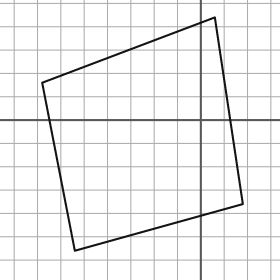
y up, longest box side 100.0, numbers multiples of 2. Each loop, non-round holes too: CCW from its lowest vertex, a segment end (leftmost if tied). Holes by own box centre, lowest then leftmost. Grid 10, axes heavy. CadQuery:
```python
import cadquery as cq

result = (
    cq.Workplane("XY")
    .moveTo(-54.0, -56.0)
    .lineTo(18.0, -36.0)
    .lineTo(6.0, 44.0)
    .lineTo(-68.0, 16.0)
    .close()
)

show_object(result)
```